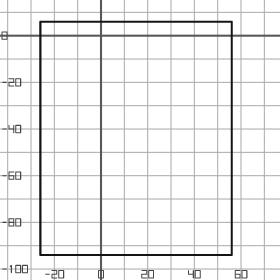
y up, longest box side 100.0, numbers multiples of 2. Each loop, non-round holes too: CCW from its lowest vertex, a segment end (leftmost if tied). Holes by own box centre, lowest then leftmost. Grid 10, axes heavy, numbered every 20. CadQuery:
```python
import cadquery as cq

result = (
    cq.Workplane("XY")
    .moveTo(-26.0, -94.0)
    .lineTo(56.0, -94.0)
    .lineTo(56.0, 6.0)
    .lineTo(-26.0, 6.0)
    .close()
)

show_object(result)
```